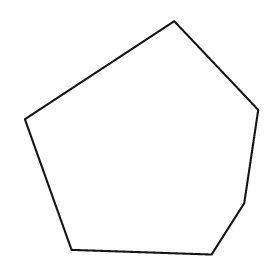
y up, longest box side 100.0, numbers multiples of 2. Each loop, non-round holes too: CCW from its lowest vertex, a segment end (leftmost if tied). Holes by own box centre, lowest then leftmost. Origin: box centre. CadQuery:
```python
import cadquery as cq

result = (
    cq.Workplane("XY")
    .moveTo(30.0, -50.0)
    .lineTo(44.0, -28.0)
    .lineTo(50.0, 12.0)
    .lineTo(14.0, 50.0)
    .lineTo(-50.0, 8.0)
    .lineTo(-30.0, -48.0)
    .close()
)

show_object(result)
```